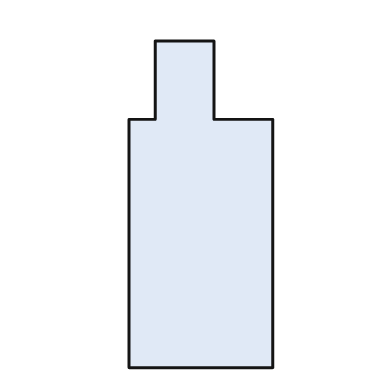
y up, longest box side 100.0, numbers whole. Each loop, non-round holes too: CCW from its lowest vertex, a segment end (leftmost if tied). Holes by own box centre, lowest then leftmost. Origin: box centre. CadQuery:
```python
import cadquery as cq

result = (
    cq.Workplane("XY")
    .moveTo(-22.0, -50.0)
    .lineTo(22.0, -50.0)
    .lineTo(22.0, 26.0)
    .lineTo(4.0, 26.0)
    .lineTo(4.0, 50.0)
    .lineTo(-14.0, 50.0)
    .lineTo(-14.0, 26.0)
    .lineTo(-22.0, 26.0)
    .close()
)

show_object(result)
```